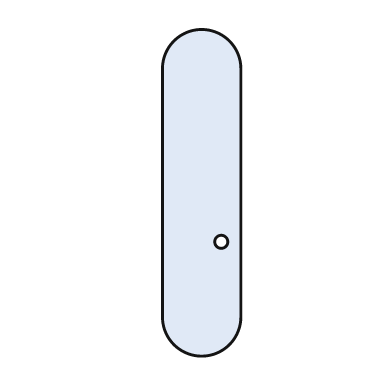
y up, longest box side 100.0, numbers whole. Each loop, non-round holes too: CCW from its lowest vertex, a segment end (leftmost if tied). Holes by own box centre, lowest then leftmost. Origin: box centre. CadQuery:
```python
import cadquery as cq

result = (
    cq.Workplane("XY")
    .moveTo(-12.0, -38.0)
    .threePointArc((0.0, -50.0), (12.0, -38.0))
    .lineTo(12.0, 38.0)
    .threePointArc((0.0, 50.0), (-12.0, 38.0))
    .close()
    .moveTo(6.0, -15.0)
    .circle(2.0)
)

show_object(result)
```